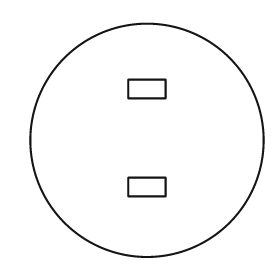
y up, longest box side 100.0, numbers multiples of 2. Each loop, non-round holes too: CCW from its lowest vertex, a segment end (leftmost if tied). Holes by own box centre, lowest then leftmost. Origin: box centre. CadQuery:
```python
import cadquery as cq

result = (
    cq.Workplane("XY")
    .moveTo(0.0, 0.0)
    .circle(50.0)
    .moveTo(-8.0, -24.0)
    .lineTo(8.0, -24.0)
    .lineTo(8.0, -16.0)
    .lineTo(-8.0, -16.0)
    .close()
    .moveTo(-8.0, 18.0)
    .lineTo(8.0, 18.0)
    .lineTo(8.0, 26.0)
    .lineTo(-8.0, 26.0)
    .close()
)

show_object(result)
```